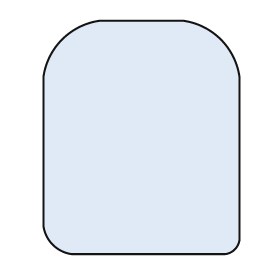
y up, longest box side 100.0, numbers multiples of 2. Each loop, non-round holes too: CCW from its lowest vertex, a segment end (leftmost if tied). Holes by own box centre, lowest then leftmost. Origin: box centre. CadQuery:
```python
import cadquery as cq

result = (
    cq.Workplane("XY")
    .moveTo(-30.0, -50.0)
    .lineTo(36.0, -50.0)
    .threePointArc((40.0, -48.0), (42.0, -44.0))
    .lineTo(42.0, 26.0)
    .threePointArc((34.0, 42.0), (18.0, 50.0))
    .lineTo(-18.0, 50.0)
    .threePointArc((-34.0, 42.0), (-42.0, 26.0))
    .lineTo(-42.0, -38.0)
    .threePointArc((-38.0, -46.0), (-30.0, -50.0))
    .close()
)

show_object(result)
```